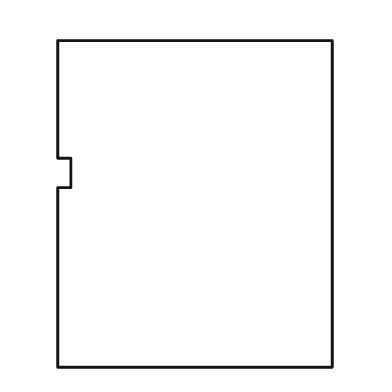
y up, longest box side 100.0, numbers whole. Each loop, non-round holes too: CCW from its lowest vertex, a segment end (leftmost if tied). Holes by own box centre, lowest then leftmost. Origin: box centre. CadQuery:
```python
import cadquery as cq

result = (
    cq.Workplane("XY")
    .moveTo(-42.0, -50.0)
    .lineTo(42.0, -50.0)
    .lineTo(42.0, 50.0)
    .lineTo(-42.0, 50.0)
    .lineTo(-42.0, 14.0)
    .lineTo(-38.0, 14.0)
    .lineTo(-38.0, 5.0)
    .lineTo(-42.0, 5.0)
    .close()
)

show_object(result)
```